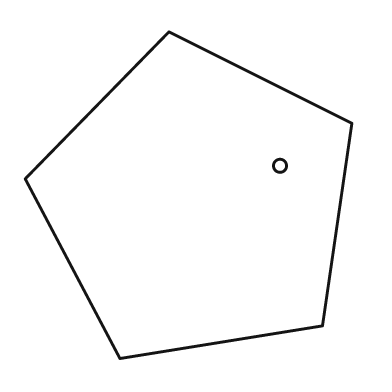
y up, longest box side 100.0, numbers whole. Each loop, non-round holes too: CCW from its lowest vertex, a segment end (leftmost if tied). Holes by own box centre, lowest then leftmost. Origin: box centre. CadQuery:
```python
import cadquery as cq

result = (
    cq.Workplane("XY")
    .moveTo(-21.0, -50.0)
    .lineTo(41.0, -40.0)
    .lineTo(50.0, 22.0)
    .lineTo(-6.0, 50.0)
    .lineTo(-50.0, 5.0)
    .close()
    .moveTo(28.0, 9.0)
    .circle(2.0)
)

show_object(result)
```